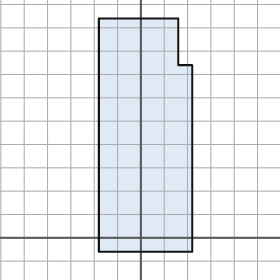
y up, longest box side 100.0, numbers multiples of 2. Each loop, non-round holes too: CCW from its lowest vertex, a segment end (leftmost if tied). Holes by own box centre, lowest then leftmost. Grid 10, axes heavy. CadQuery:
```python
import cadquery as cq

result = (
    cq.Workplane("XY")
    .moveTo(-18.0, -6.0)
    .lineTo(22.0, -6.0)
    .lineTo(22.0, 74.0)
    .lineTo(16.0, 74.0)
    .lineTo(16.0, 94.0)
    .lineTo(-18.0, 94.0)
    .close()
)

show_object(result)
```